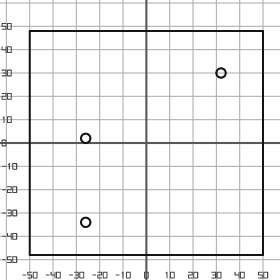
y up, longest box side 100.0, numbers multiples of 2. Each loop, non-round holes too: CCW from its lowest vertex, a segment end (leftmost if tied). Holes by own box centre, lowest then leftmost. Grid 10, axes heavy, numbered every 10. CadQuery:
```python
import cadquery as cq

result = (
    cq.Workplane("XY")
    .moveTo(-50.0, -48.0)
    .lineTo(50.0, -48.0)
    .lineTo(50.0, 48.0)
    .lineTo(-50.0, 48.0)
    .close()
    .moveTo(-26.0, -34.0)
    .circle(2.0)
    .moveTo(-26.0, 2.0)
    .circle(2.0)
    .moveTo(32.0, 30.0)
    .circle(2.0)
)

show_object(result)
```